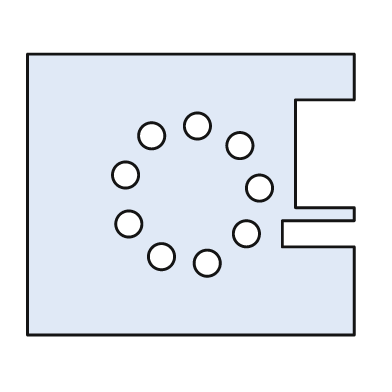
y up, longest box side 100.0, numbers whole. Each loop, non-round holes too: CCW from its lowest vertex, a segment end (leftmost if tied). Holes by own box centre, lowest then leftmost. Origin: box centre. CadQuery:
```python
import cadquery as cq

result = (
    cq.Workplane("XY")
    .moveTo(-50.0, -43.0)
    .lineTo(50.0, -43.0)
    .lineTo(50.0, -16.0)
    .lineTo(28.0, -16.0)
    .lineTo(28.0, -8.0)
    .lineTo(50.0, -8.0)
    .lineTo(50.0, -4.0)
    .lineTo(32.0, -4.0)
    .lineTo(32.0, 29.0)
    .lineTo(50.0, 29.0)
    .lineTo(50.0, 43.0)
    .lineTo(-50.0, 43.0)
    .close()
    .moveTo(5.0, -21.0)
    .circle(4.0)
    .moveTo(-9.0, -19.0)
    .circle(4.0)
    .moveTo(17.0, -12.0)
    .circle(4.0)
    .moveTo(-19.0, -9.0)
    .circle(4.0)
    .moveTo(21.0, 2.0)
    .circle(4.0)
    .moveTo(-20.0, 6.0)
    .circle(4.0)
    .moveTo(15.0, 15.0)
    .circle(4.0)
    .moveTo(-12.0, 18.0)
    .circle(4.0)
    .moveTo(2.0, 21.0)
    .circle(4.0)
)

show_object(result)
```